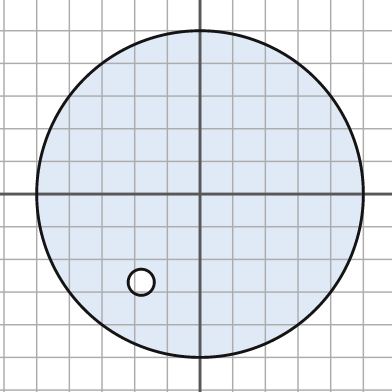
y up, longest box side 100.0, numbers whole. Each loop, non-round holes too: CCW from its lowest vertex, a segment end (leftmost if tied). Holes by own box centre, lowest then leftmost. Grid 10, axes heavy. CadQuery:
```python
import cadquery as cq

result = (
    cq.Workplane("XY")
    .moveTo(0.0, 0.0)
    .circle(50.0)
    .moveTo(-18.0, -27.0)
    .circle(4.0)
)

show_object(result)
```